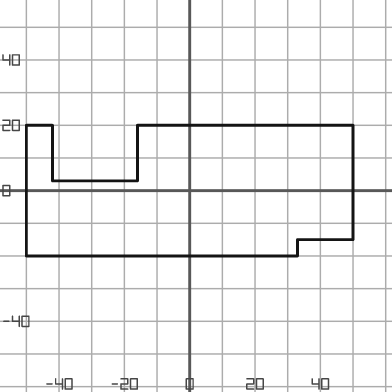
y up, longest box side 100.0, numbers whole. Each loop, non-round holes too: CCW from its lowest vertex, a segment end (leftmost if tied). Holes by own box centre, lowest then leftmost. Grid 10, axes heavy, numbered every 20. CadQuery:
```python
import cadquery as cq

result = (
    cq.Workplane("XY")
    .moveTo(-50.0, -20.0)
    .lineTo(33.0, -20.0)
    .lineTo(33.0, -15.0)
    .lineTo(50.0, -15.0)
    .lineTo(50.0, 20.0)
    .lineTo(-16.0, 20.0)
    .lineTo(-16.0, 3.0)
    .lineTo(-42.0, 3.0)
    .lineTo(-42.0, 20.0)
    .lineTo(-50.0, 20.0)
    .close()
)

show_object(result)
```